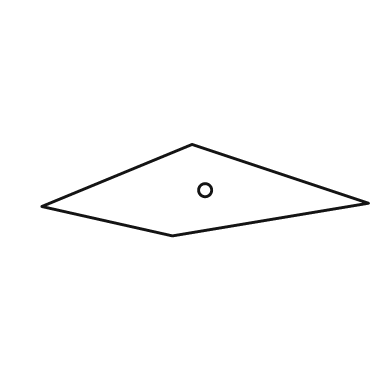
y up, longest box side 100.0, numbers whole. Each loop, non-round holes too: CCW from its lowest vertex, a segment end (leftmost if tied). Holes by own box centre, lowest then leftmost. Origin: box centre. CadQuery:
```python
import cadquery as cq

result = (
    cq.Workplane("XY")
    .moveTo(-10.0, -14.0)
    .lineTo(50.0, -4.0)
    .lineTo(-4.0, 14.0)
    .lineTo(-50.0, -5.0)
    .close()
    .moveTo(0.0, 0.0)
    .circle(2.0)
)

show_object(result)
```